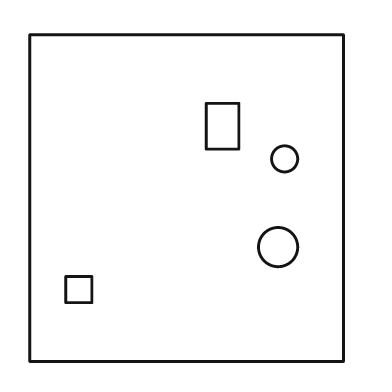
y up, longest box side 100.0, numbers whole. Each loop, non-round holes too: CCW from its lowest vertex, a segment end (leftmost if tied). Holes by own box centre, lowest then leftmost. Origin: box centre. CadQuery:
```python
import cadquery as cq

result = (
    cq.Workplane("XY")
    .moveTo(-48.0, -50.0)
    .lineTo(48.0, -50.0)
    .lineTo(48.0, 50.0)
    .lineTo(-48.0, 50.0)
    .close()
    .moveTo(-37.0, -32.0)
    .lineTo(-29.0, -32.0)
    .lineTo(-29.0, -24.0)
    .lineTo(-37.0, -24.0)
    .close()
    .moveTo(28.0, -15.0)
    .circle(6.0)
    .moveTo(30.0, 12.0)
    .circle(4.0)
    .moveTo(6.0, 15.0)
    .lineTo(16.0, 15.0)
    .lineTo(16.0, 29.0)
    .lineTo(6.0, 29.0)
    .close()
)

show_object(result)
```